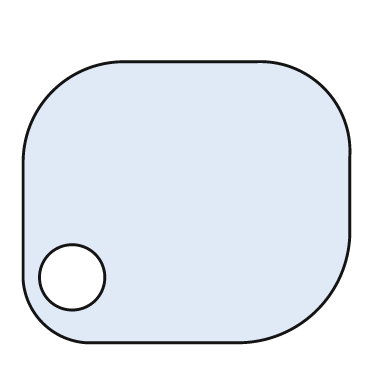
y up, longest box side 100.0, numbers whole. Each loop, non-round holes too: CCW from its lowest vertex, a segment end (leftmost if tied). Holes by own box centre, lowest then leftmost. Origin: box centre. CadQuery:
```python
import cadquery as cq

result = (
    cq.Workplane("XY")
    .moveTo(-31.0, -43.0)
    .lineTo(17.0, -43.0)
    .threePointArc((40.0, -33.0), (50.0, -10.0))
    .lineTo(50.0, 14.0)
    .threePointArc((42.0, 35.0), (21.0, 43.0))
    .lineTo(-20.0, 43.0)
    .threePointArc((-41.0, 34.0), (-50.0, 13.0))
    .lineTo(-50.0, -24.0)
    .threePointArc((-44.0, -37.0), (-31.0, -43.0))
    .close()
    .moveTo(-35.0, -23.0)
    .circle(10.0)
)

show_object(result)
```